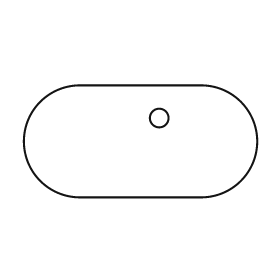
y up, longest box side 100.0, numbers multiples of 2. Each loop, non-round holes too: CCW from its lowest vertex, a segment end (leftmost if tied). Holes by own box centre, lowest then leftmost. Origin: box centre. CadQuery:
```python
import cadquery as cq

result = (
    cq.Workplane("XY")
    .moveTo(-26.0, -24.0)
    .lineTo(26.0, -24.0)
    .threePointArc((50.0, 0.0), (26.0, 24.0))
    .lineTo(-26.0, 24.0)
    .threePointArc((-50.0, 0.0), (-26.0, -24.0))
    .close()
    .moveTo(8.0, 10.0)
    .circle(4.0)
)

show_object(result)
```